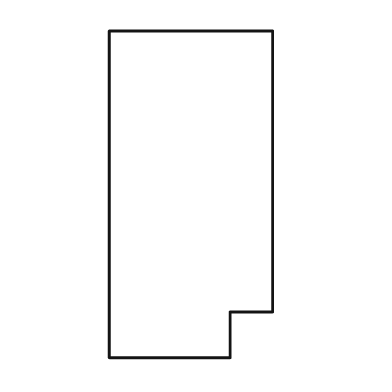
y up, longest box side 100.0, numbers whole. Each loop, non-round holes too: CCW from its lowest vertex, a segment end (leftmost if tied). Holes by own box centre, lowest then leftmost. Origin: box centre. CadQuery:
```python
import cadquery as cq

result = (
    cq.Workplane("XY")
    .moveTo(-25.0, -50.0)
    .lineTo(12.0, -50.0)
    .lineTo(12.0, -36.0)
    .lineTo(25.0, -36.0)
    .lineTo(25.0, 50.0)
    .lineTo(-25.0, 50.0)
    .close()
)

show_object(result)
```